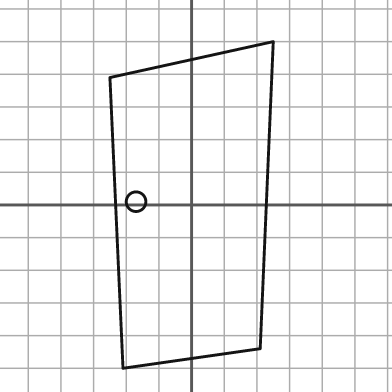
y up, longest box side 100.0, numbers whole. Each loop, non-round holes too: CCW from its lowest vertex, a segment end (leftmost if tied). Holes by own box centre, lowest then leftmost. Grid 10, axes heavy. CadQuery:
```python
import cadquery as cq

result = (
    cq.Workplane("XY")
    .moveTo(-21.0, -50.0)
    .lineTo(21.0, -44.0)
    .lineTo(25.0, 50.0)
    .lineTo(-25.0, 39.0)
    .close()
    .moveTo(-17.0, 1.0)
    .circle(3.0)
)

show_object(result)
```